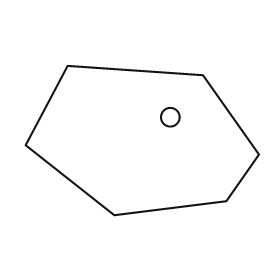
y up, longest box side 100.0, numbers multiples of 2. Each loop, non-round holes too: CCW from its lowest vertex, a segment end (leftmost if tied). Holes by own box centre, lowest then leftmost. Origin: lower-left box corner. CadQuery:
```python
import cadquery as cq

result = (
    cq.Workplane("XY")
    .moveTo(38.0, 0.0)
    .lineTo(86.0, 6.0)
    .lineTo(100.0, 26.0)
    .lineTo(76.0, 60.0)
    .lineTo(18.0, 64.0)
    .lineTo(0.0, 30.0)
    .close()
    .moveTo(62.0, 42.0)
    .circle(4.0)
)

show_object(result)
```